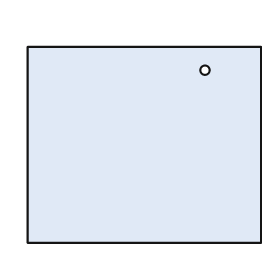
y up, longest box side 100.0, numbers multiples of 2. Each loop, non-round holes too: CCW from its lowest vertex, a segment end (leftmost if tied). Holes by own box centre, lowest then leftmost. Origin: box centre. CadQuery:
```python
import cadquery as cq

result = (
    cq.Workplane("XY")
    .moveTo(-50.0, -42.0)
    .lineTo(50.0, -42.0)
    .lineTo(50.0, 42.0)
    .lineTo(-50.0, 42.0)
    .close()
    .moveTo(26.0, 32.0)
    .circle(2.0)
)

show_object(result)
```